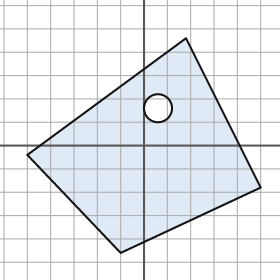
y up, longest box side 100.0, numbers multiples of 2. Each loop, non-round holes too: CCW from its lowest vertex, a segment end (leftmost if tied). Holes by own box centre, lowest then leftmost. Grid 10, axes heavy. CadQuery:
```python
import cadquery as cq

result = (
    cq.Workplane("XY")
    .moveTo(-10.0, -46.0)
    .lineTo(50.0, -18.0)
    .lineTo(18.0, 46.0)
    .lineTo(-50.0, -4.0)
    .close()
    .moveTo(6.0, 16.0)
    .circle(6.0)
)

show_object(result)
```